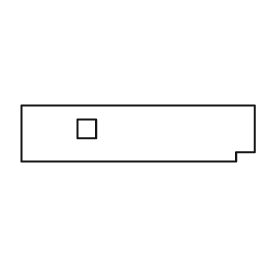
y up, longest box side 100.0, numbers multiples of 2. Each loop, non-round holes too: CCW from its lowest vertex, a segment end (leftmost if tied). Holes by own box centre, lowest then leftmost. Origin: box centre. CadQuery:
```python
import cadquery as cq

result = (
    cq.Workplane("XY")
    .moveTo(-50.0, -12.0)
    .lineTo(42.0, -12.0)
    .lineTo(42.0, -8.0)
    .lineTo(50.0, -8.0)
    .lineTo(50.0, 12.0)
    .lineTo(-50.0, 12.0)
    .close()
    .moveTo(-26.0, -2.0)
    .lineTo(-18.0, -2.0)
    .lineTo(-18.0, 6.0)
    .lineTo(-26.0, 6.0)
    .close()
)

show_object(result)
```